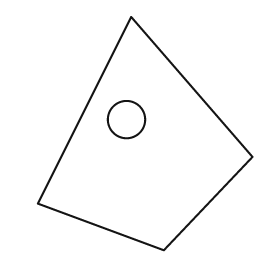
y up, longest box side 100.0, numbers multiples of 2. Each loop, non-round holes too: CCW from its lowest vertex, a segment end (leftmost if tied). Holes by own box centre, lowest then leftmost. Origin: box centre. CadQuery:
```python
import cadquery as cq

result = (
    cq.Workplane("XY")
    .moveTo(8.0, -50.0)
    .lineTo(46.0, -10.0)
    .lineTo(-6.0, 50.0)
    .lineTo(-46.0, -30.0)
    .close()
    .moveTo(-8.0, 6.0)
    .circle(8.0)
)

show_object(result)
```